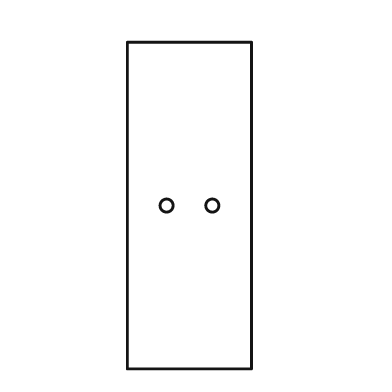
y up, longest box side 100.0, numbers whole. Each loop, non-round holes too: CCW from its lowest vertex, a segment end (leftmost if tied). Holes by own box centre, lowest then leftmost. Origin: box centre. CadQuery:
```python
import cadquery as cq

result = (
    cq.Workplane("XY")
    .moveTo(-19.0, -50.0)
    .lineTo(19.0, -50.0)
    .lineTo(19.0, 50.0)
    .lineTo(-19.0, 50.0)
    .close()
    .moveTo(-7.0, 0.0)
    .circle(2.0)
    .moveTo(7.0, 0.0)
    .circle(2.0)
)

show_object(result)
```